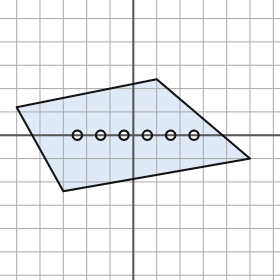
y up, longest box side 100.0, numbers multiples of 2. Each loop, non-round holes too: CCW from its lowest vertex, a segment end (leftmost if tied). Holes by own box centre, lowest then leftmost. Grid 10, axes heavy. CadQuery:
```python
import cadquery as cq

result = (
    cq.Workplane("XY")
    .moveTo(-30.0, -24.0)
    .lineTo(50.0, -10.0)
    .lineTo(10.0, 24.0)
    .lineTo(-50.0, 12.0)
    .close()
    .moveTo(-24.0, 0.0)
    .circle(2.0)
    .moveTo(-14.0, 0.0)
    .circle(2.0)
    .moveTo(-4.0, 0.0)
    .circle(2.0)
    .moveTo(6.0, 0.0)
    .circle(2.0)
    .moveTo(16.0, 0.0)
    .circle(2.0)
    .moveTo(26.0, 0.0)
    .circle(2.0)
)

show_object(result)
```